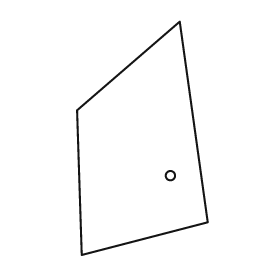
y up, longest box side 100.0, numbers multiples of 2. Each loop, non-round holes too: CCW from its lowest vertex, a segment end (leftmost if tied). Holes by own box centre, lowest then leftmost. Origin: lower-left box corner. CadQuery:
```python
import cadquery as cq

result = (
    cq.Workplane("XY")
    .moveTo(2.0, 0.0)
    .lineTo(56.0, 14.0)
    .lineTo(44.0, 100.0)
    .lineTo(0.0, 62.0)
    .close()
    .moveTo(40.0, 34.0)
    .circle(2.0)
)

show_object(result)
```